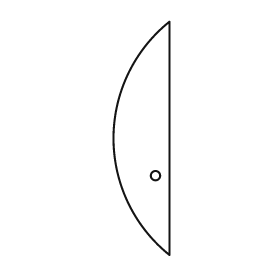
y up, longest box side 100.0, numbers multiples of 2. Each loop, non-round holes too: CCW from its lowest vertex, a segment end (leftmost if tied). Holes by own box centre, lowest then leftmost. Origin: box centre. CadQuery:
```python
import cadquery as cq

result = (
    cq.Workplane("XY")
    .moveTo(12.0, -50.0)
    .lineTo(12.0, 50.0)
    .threePointArc((-12.0, 0.0), (12.0, -50.0))
    .close()
    .moveTo(6.0, -16.0)
    .circle(2.0)
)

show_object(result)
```